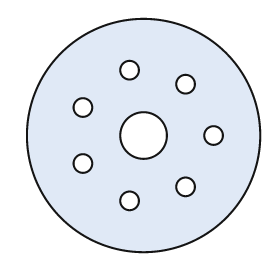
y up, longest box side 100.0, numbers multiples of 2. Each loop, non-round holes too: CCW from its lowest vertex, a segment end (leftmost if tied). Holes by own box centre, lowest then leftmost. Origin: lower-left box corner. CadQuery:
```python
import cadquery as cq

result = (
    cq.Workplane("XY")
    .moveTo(50.0, 50.0)
    .circle(50.0)
    .moveTo(44.0, 22.0)
    .circle(4.0)
    .moveTo(68.0, 28.0)
    .circle(4.0)
    .moveTo(24.0, 38.0)
    .circle(4.0)
    .moveTo(50.0, 50.0)
    .circle(10.0)
    .moveTo(80.0, 50.0)
    .circle(4.0)
    .moveTo(24.0, 62.0)
    .circle(4.0)
    .moveTo(68.0, 72.0)
    .circle(4.0)
    .moveTo(44.0, 78.0)
    .circle(4.0)
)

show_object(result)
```